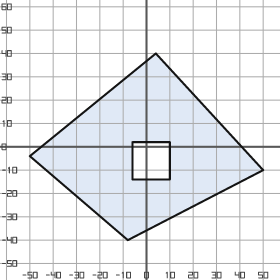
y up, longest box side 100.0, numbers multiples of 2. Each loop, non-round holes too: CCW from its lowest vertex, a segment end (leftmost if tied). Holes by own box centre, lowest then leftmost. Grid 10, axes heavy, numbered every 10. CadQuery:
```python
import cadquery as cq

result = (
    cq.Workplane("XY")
    .moveTo(-8.0, -40.0)
    .lineTo(50.0, -10.0)
    .lineTo(4.0, 40.0)
    .lineTo(-50.0, -4.0)
    .close()
    .moveTo(-6.0, -14.0)
    .lineTo(10.0, -14.0)
    .lineTo(10.0, 2.0)
    .lineTo(-6.0, 2.0)
    .close()
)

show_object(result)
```